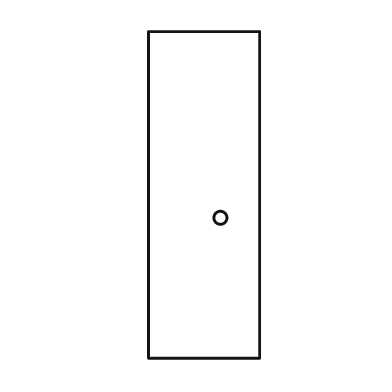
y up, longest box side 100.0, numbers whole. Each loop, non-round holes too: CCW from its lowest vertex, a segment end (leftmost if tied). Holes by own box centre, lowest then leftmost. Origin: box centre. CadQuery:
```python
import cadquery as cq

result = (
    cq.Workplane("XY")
    .moveTo(-17.0, -50.0)
    .lineTo(17.0, -50.0)
    .lineTo(17.0, 50.0)
    .lineTo(-17.0, 50.0)
    .close()
    .moveTo(5.0, -7.0)
    .circle(2.0)
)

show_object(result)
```